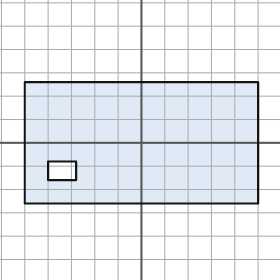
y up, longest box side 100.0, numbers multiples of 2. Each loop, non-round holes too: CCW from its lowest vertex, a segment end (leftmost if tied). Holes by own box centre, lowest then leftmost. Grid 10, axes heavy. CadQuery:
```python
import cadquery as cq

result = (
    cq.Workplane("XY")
    .moveTo(-50.0, -26.0)
    .lineTo(50.0, -26.0)
    .lineTo(50.0, 26.0)
    .lineTo(-50.0, 26.0)
    .close()
    .moveTo(-40.0, -16.0)
    .lineTo(-28.0, -16.0)
    .lineTo(-28.0, -8.0)
    .lineTo(-40.0, -8.0)
    .close()
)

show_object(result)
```